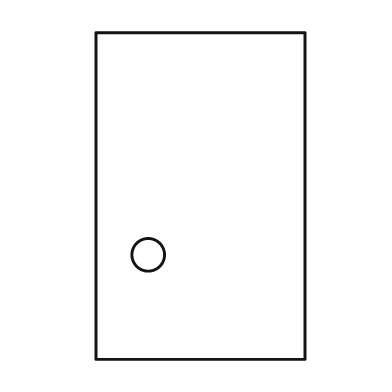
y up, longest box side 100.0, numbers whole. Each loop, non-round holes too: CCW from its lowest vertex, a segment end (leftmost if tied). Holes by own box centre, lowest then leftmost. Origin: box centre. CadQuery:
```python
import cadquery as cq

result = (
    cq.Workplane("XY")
    .moveTo(-32.0, -50.0)
    .lineTo(32.0, -50.0)
    .lineTo(32.0, 50.0)
    .lineTo(-32.0, 50.0)
    .close()
    .moveTo(-16.0, -18.0)
    .circle(5.0)
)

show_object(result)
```